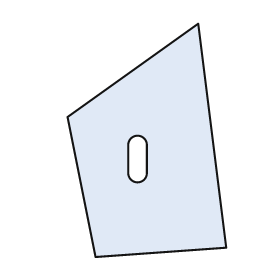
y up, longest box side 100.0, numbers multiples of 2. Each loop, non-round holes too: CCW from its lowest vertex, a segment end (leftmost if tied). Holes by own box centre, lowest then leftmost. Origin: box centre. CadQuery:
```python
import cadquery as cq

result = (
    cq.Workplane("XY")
    .moveTo(-22.0, -50.0)
    .lineTo(34.0, -46.0)
    .lineTo(22.0, 50.0)
    .lineTo(-34.0, 10.0)
    .close()
    .moveTo(-8.0, -14.0)
    .threePointArc((-4.0, -18.0), (0.0, -14.0))
    .lineTo(0.0, -2.0)
    .threePointArc((-4.0, 2.0), (-8.0, -2.0))
    .close()
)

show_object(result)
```